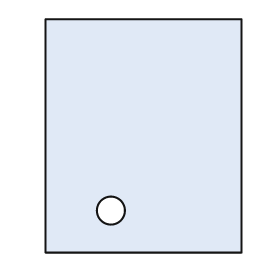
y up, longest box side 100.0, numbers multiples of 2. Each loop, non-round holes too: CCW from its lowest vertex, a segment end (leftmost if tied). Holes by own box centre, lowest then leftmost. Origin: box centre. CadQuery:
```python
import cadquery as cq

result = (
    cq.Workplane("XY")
    .moveTo(-42.0, -50.0)
    .lineTo(42.0, -50.0)
    .lineTo(42.0, 50.0)
    .lineTo(-42.0, 50.0)
    .close()
    .moveTo(-14.0, -32.0)
    .circle(6.0)
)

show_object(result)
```